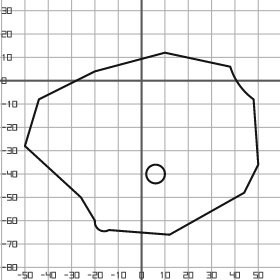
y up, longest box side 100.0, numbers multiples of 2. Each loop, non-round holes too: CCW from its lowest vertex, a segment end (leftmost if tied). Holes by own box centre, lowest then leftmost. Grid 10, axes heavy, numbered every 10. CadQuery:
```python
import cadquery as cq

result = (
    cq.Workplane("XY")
    .moveTo(12.0, -66.0)
    .lineTo(44.0, -48.0)
    .lineTo(50.0, -36.0)
    .lineTo(48.0, -8.0)
    .threePointArc((42.0, -2.0), (38.0, 6.0))
    .lineTo(10.0, 12.0)
    .lineTo(-20.0, 4.0)
    .lineTo(-44.0, -8.0)
    .lineTo(-50.0, -28.0)
    .lineTo(-26.0, -50.0)
    .lineTo(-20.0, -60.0)
    .threePointArc((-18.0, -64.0), (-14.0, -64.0))
    .close()
    .moveTo(6.0, -40.0)
    .circle(4.0)
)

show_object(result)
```